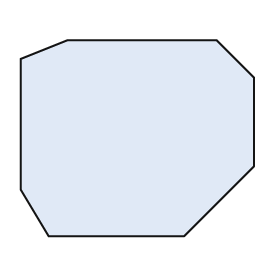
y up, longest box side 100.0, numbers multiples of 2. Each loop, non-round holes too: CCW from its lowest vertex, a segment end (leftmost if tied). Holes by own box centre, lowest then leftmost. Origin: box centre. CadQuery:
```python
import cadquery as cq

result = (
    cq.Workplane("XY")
    .moveTo(-38.0, -42.0)
    .lineTo(20.0, -42.0)
    .lineTo(50.0, -12.0)
    .lineTo(50.0, 26.0)
    .lineTo(34.0, 42.0)
    .lineTo(-30.0, 42.0)
    .lineTo(-50.0, 34.0)
    .lineTo(-50.0, -22.0)
    .close()
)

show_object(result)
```